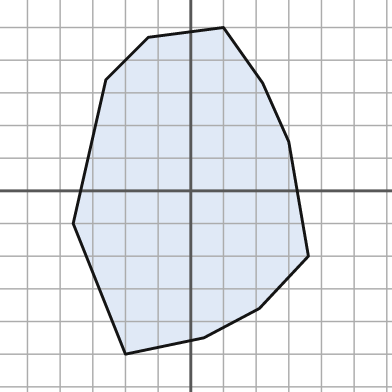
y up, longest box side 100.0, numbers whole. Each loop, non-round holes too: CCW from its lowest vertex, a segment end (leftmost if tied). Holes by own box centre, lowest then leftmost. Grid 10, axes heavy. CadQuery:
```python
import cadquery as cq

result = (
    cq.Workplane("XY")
    .moveTo(-20.0, -50.0)
    .lineTo(4.0, -45.0)
    .lineTo(21.0, -36.0)
    .lineTo(36.0, -20.0)
    .lineTo(30.0, 15.0)
    .lineTo(22.0, 33.0)
    .lineTo(10.0, 50.0)
    .lineTo(-13.0, 47.0)
    .lineTo(-26.0, 34.0)
    .lineTo(-36.0, -10.0)
    .close()
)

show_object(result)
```